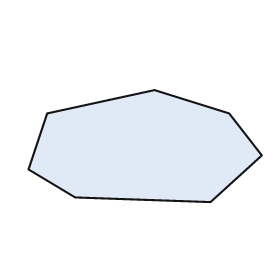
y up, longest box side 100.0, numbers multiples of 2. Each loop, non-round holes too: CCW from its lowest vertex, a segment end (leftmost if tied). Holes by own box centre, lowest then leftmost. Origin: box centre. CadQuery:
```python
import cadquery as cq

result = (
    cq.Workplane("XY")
    .moveTo(28.0, -24.0)
    .lineTo(50.0, -4.0)
    .lineTo(36.0, 14.0)
    .lineTo(4.0, 24.0)
    .lineTo(-42.0, 14.0)
    .lineTo(-50.0, -10.0)
    .lineTo(-30.0, -22.0)
    .close()
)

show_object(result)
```